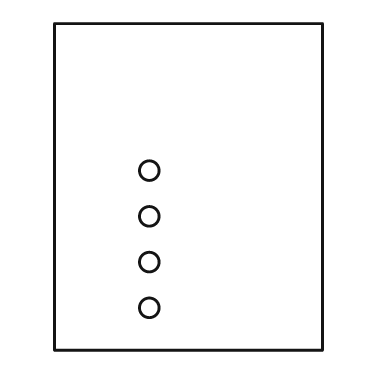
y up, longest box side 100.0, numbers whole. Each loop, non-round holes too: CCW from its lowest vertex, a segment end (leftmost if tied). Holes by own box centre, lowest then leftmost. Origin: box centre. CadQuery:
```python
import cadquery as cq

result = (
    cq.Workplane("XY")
    .moveTo(-41.0, -50.0)
    .lineTo(41.0, -50.0)
    .lineTo(41.0, 50.0)
    .lineTo(-41.0, 50.0)
    .close()
    .moveTo(-12.0, -37.0)
    .circle(3.0)
    .moveTo(-12.0, -23.0)
    .circle(3.0)
    .moveTo(-12.0, -9.0)
    .circle(3.0)
    .moveTo(-12.0, 5.0)
    .circle(3.0)
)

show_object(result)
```